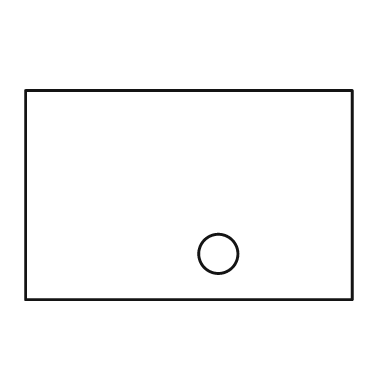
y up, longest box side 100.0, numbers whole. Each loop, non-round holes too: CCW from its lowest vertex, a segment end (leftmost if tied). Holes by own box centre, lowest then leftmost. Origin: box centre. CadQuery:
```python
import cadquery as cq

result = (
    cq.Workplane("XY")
    .moveTo(-50.0, -32.0)
    .lineTo(50.0, -32.0)
    .lineTo(50.0, 32.0)
    .lineTo(-50.0, 32.0)
    .close()
    .moveTo(9.0, -18.0)
    .circle(6.0)
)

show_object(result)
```